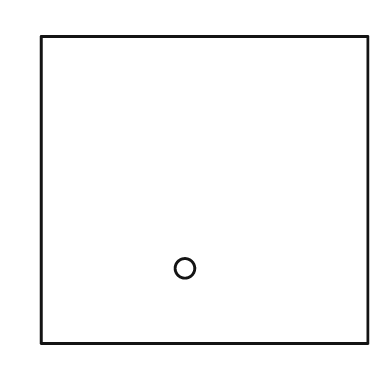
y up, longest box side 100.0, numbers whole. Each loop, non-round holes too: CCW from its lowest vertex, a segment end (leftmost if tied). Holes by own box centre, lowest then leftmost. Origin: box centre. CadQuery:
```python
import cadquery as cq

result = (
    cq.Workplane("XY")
    .moveTo(-50.0, -47.0)
    .lineTo(50.0, -47.0)
    .lineTo(50.0, 47.0)
    .lineTo(-50.0, 47.0)
    .close()
    .moveTo(-6.0, -24.0)
    .circle(3.0)
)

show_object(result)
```